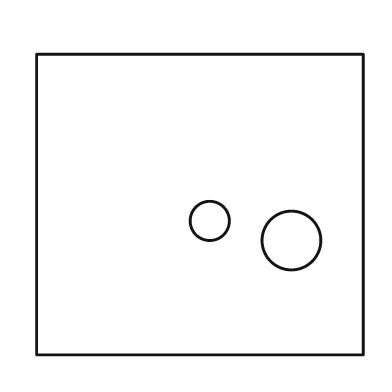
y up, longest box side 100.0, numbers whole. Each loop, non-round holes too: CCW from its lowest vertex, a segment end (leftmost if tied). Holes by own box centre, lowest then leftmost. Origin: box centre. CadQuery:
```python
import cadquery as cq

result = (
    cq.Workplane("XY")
    .moveTo(-50.0, -46.0)
    .lineTo(50.0, -46.0)
    .lineTo(50.0, 46.0)
    .lineTo(-50.0, 46.0)
    .close()
    .moveTo(28.0, -11.0)
    .circle(9.0)
    .moveTo(3.0, -5.0)
    .circle(6.0)
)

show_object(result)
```